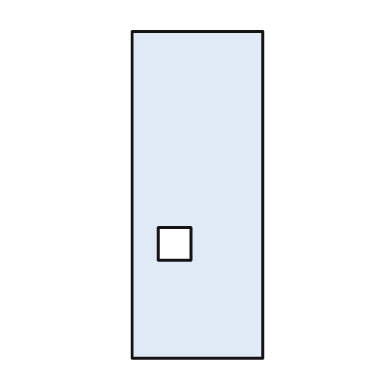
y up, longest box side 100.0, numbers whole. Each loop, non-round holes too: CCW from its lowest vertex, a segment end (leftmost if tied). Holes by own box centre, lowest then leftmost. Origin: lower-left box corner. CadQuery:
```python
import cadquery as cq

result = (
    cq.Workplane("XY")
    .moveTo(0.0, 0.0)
    .lineTo(40.0, 0.0)
    .lineTo(40.0, 100.0)
    .lineTo(0.0, 100.0)
    .close()
    .moveTo(8.0, 30.0)
    .lineTo(18.0, 30.0)
    .lineTo(18.0, 40.0)
    .lineTo(8.0, 40.0)
    .close()
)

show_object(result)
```